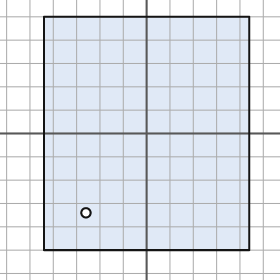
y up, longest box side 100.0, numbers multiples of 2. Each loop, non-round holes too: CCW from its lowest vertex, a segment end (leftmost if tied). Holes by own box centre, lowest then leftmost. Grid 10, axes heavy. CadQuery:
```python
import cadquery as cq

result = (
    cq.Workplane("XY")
    .moveTo(-44.0, -50.0)
    .lineTo(44.0, -50.0)
    .lineTo(44.0, 50.0)
    .lineTo(-44.0, 50.0)
    .close()
    .moveTo(-26.0, -34.0)
    .circle(2.0)
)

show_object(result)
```